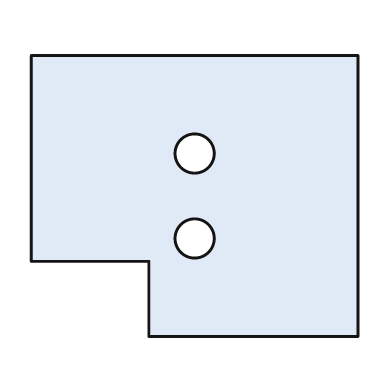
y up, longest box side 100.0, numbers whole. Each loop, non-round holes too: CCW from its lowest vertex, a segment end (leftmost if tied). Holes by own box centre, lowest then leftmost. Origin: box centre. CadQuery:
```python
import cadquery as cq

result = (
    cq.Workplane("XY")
    .moveTo(-14.0, -43.0)
    .lineTo(50.0, -43.0)
    .lineTo(50.0, 43.0)
    .lineTo(-50.0, 43.0)
    .lineTo(-50.0, -20.0)
    .lineTo(-14.0, -20.0)
    .close()
    .moveTo(0.0, -13.0)
    .circle(6.0)
    .moveTo(0.0, 13.0)
    .circle(6.0)
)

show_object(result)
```